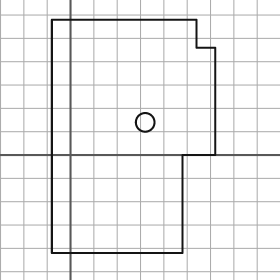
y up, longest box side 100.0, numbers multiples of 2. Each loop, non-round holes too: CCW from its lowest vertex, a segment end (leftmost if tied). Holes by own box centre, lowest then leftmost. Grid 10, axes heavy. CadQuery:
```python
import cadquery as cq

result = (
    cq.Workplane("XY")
    .moveTo(-8.0, -42.0)
    .lineTo(48.0, -42.0)
    .lineTo(48.0, 0.0)
    .lineTo(62.0, 0.0)
    .lineTo(62.0, 46.0)
    .lineTo(54.0, 46.0)
    .lineTo(54.0, 58.0)
    .lineTo(-8.0, 58.0)
    .close()
    .moveTo(32.0, 14.0)
    .circle(4.0)
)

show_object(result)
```